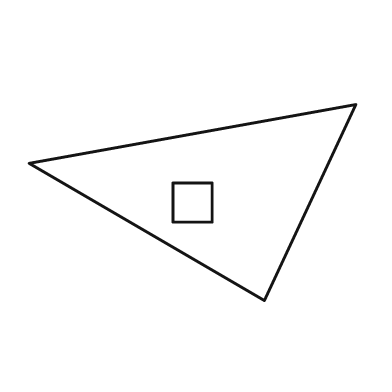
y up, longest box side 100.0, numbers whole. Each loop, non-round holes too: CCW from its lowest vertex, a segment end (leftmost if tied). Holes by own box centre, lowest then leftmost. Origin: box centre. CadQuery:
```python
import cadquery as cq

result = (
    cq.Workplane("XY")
    .moveTo(22.0, -30.0)
    .lineTo(50.0, 30.0)
    .lineTo(-50.0, 12.0)
    .close()
    .moveTo(-6.0, -6.0)
    .lineTo(6.0, -6.0)
    .lineTo(6.0, 6.0)
    .lineTo(-6.0, 6.0)
    .close()
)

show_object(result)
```